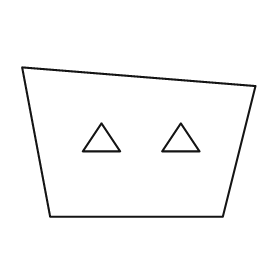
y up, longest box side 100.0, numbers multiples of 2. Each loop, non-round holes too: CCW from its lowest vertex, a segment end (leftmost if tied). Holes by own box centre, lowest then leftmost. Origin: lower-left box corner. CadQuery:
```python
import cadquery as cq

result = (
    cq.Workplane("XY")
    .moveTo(12.0, 0.0)
    .lineTo(86.0, 0.0)
    .lineTo(100.0, 56.0)
    .lineTo(0.0, 64.0)
    .close()
    .moveTo(26.0, 28.0)
    .lineTo(42.0, 28.0)
    .lineTo(34.0, 40.0)
    .close()
    .moveTo(60.0, 28.0)
    .lineTo(76.0, 28.0)
    .lineTo(68.0, 40.0)
    .close()
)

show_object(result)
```